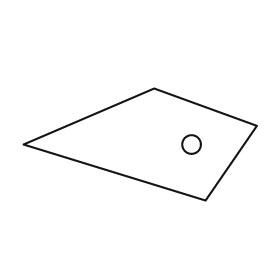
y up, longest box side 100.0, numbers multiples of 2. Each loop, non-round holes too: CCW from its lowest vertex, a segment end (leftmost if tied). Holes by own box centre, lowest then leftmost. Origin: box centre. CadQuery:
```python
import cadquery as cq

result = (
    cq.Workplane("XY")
    .moveTo(28.0, -24.0)
    .lineTo(50.0, 8.0)
    .lineTo(6.0, 24.0)
    .lineTo(-50.0, 0.0)
    .close()
    .moveTo(22.0, 0.0)
    .circle(4.0)
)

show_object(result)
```